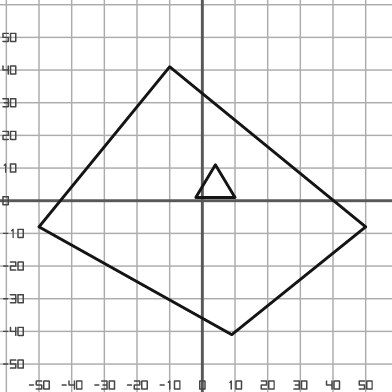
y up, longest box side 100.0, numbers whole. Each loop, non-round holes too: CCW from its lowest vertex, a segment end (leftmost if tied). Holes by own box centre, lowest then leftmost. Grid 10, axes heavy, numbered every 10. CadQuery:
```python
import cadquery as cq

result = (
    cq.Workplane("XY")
    .moveTo(9.0, -41.0)
    .lineTo(50.0, -8.0)
    .lineTo(-10.0, 41.0)
    .lineTo(-50.0, -8.0)
    .close()
    .moveTo(-2.0, 1.0)
    .lineTo(10.0, 1.0)
    .lineTo(4.0, 11.0)
    .close()
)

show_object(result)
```